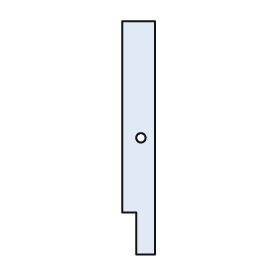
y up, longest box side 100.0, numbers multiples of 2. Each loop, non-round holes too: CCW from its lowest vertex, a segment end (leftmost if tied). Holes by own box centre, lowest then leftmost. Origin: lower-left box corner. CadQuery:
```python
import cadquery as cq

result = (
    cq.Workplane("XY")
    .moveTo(6.0, 0.0)
    .lineTo(14.0, 0.0)
    .lineTo(14.0, 100.0)
    .lineTo(0.0, 100.0)
    .lineTo(0.0, 18.0)
    .lineTo(6.0, 18.0)
    .close()
    .moveTo(8.0, 50.0)
    .circle(2.0)
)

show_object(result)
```